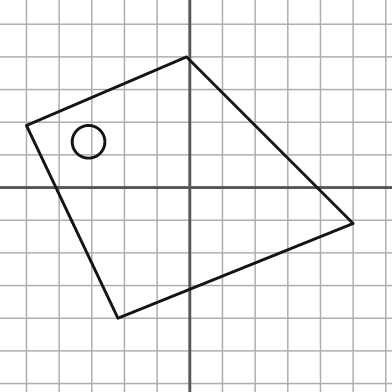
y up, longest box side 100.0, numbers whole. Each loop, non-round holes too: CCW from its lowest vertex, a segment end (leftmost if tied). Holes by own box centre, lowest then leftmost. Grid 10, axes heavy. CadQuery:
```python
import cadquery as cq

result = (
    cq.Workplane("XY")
    .moveTo(-22.0, -40.0)
    .lineTo(50.0, -11.0)
    .lineTo(-1.0, 40.0)
    .lineTo(-50.0, 19.0)
    .close()
    .moveTo(-31.0, 14.0)
    .circle(5.0)
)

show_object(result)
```